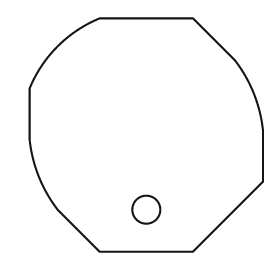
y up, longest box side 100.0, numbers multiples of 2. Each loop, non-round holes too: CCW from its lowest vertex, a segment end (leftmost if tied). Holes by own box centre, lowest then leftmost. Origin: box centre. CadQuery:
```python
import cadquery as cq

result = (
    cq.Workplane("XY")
    .moveTo(-20.0, -50.0)
    .lineTo(20.0, -50.0)
    .lineTo(50.0, -20.0)
    .lineTo(50.0, 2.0)
    .threePointArc((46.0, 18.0), (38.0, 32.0))
    .lineTo(20.0, 50.0)
    .lineTo(-20.0, 50.0)
    .threePointArc((-38.0, 38.0), (-50.0, 20.0))
    .lineTo(-50.0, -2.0)
    .threePointArc((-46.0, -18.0), (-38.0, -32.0))
    .close()
    .moveTo(0.0, -32.0)
    .circle(6.0)
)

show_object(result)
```